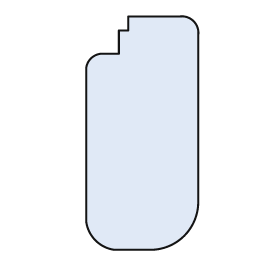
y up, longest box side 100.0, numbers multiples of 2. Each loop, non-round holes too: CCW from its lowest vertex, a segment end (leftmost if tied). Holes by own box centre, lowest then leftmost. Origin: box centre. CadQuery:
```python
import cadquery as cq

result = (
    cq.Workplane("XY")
    .moveTo(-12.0, -50.0)
    .lineTo(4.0, -50.0)
    .threePointArc((18.0, -44.0), (24.0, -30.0))
    .lineTo(24.0, 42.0)
    .threePointArc((22.0, 48.0), (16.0, 50.0))
    .lineTo(-6.0, 50.0)
    .lineTo(-6.0, 44.0)
    .lineTo(-10.0, 44.0)
    .lineTo(-10.0, 34.0)
    .lineTo(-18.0, 34.0)
    .threePointArc((-22.0, 32.0), (-24.0, 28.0))
    .lineTo(-24.0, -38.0)
    .threePointArc((-20.0, -46.0), (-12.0, -50.0))
    .close()
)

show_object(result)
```